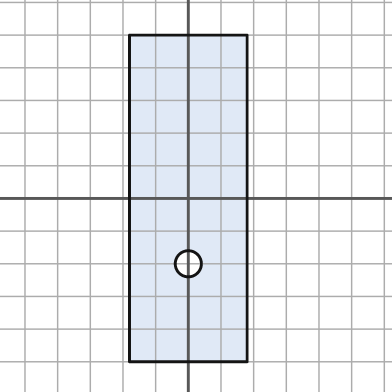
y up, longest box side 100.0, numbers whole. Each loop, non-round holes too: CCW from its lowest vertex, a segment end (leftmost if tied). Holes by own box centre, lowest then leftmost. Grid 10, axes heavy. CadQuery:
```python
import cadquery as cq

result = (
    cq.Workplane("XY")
    .moveTo(-18.0, -50.0)
    .lineTo(18.0, -50.0)
    .lineTo(18.0, 50.0)
    .lineTo(-18.0, 50.0)
    .close()
    .moveTo(0.0, -20.0)
    .circle(4.0)
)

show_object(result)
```